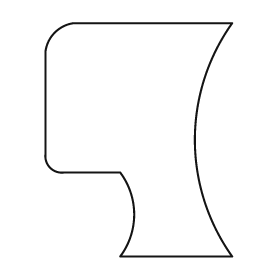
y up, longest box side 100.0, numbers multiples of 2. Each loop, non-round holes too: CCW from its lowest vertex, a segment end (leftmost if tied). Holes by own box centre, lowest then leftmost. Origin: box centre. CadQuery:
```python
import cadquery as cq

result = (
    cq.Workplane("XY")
    .moveTo(-8.0, -50.0)
    .lineTo(40.0, -50.0)
    .threePointArc((24.0, 0.0), (40.0, 50.0))
    .lineTo(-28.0, 50.0)
    .threePointArc((-36.0, 46.0), (-40.0, 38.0))
    .lineTo(-40.0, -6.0)
    .threePointArc((-38.0, -12.0), (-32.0, -14.0))
    .lineTo(-8.0, -14.0)
    .threePointArc((-2.0, -32.0), (-8.0, -50.0))
    .close()
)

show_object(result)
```